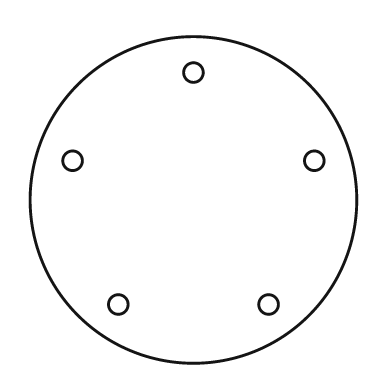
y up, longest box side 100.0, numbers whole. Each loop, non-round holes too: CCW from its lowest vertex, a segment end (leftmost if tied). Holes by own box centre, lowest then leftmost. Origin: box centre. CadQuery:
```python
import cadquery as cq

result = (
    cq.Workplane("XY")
    .moveTo(0.0, 0.0)
    .circle(50.0)
    .moveTo(-23.0, -32.0)
    .circle(3.0)
    .moveTo(23.0, -32.0)
    .circle(3.0)
    .moveTo(-37.0, 12.0)
    .circle(3.0)
    .moveTo(37.0, 12.0)
    .circle(3.0)
    .moveTo(0.0, 39.0)
    .circle(3.0)
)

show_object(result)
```